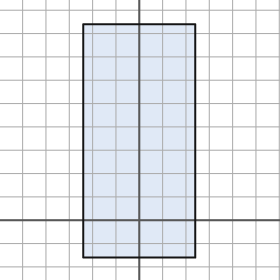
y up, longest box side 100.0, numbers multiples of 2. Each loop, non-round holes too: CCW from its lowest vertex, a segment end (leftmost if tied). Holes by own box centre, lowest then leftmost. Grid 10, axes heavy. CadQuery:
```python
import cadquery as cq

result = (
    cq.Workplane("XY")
    .moveTo(-24.0, -16.0)
    .lineTo(24.0, -16.0)
    .lineTo(24.0, 84.0)
    .lineTo(-24.0, 84.0)
    .close()
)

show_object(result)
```